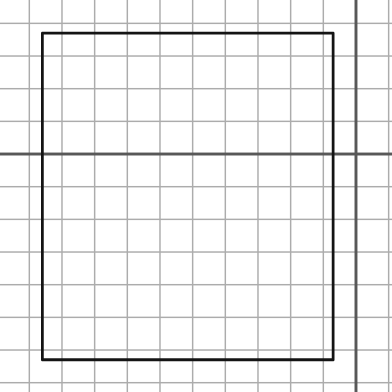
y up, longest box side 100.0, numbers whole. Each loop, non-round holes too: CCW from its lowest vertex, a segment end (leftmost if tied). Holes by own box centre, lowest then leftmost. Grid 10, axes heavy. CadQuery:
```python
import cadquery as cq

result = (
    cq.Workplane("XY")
    .moveTo(-96.0, -63.0)
    .lineTo(-7.0, -63.0)
    .lineTo(-7.0, 37.0)
    .lineTo(-96.0, 37.0)
    .close()
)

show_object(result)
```